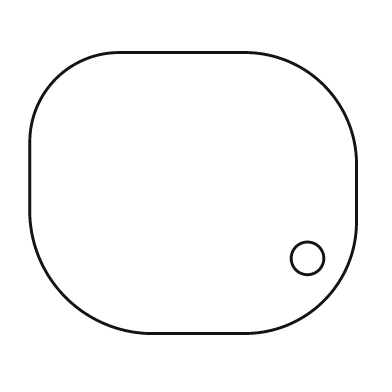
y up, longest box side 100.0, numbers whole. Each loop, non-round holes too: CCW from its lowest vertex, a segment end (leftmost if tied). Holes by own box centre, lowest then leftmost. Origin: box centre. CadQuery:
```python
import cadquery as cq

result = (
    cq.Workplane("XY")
    .moveTo(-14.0, -43.0)
    .lineTo(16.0, -43.0)
    .threePointArc((40.0, -33.0), (50.0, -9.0))
    .lineTo(50.0, 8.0)
    .threePointArc((40.0, 33.0), (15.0, 43.0))
    .lineTo(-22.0, 43.0)
    .threePointArc((-42.0, 35.0), (-50.0, 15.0))
    .lineTo(-50.0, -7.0)
    .threePointArc((-39.0, -32.0), (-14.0, -43.0))
    .close()
    .moveTo(35.0, -20.0)
    .circle(5.0)
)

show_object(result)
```